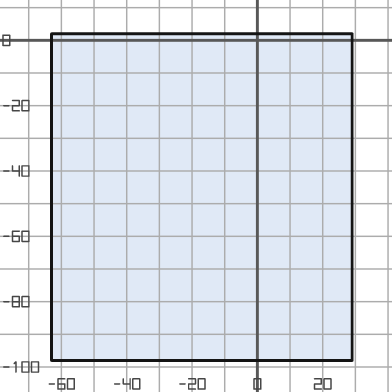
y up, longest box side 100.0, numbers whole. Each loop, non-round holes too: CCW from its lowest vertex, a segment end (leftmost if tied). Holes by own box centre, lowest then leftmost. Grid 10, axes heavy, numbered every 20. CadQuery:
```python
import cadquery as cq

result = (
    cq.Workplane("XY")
    .moveTo(-63.0, -98.0)
    .lineTo(29.0, -98.0)
    .lineTo(29.0, 2.0)
    .lineTo(-63.0, 2.0)
    .close()
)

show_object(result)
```